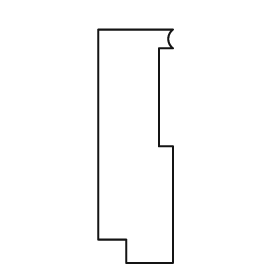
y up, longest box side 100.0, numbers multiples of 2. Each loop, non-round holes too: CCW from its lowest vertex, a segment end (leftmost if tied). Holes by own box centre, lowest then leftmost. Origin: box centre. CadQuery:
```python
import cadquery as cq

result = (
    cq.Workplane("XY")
    .moveTo(-4.0, -50.0)
    .lineTo(16.0, -50.0)
    .lineTo(16.0, 0.0)
    .lineTo(10.0, 0.0)
    .lineTo(10.0, 42.0)
    .lineTo(16.0, 42.0)
    .threePointArc((14.0, 46.0), (16.0, 50.0))
    .lineTo(-16.0, 50.0)
    .lineTo(-16.0, -40.0)
    .lineTo(-4.0, -40.0)
    .close()
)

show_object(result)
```